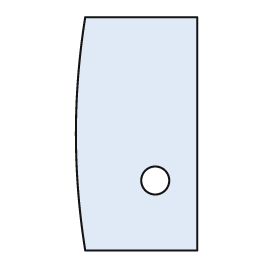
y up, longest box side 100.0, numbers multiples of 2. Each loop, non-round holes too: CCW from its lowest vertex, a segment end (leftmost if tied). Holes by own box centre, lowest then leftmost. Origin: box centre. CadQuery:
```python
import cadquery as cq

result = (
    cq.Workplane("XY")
    .moveTo(-22.0, -50.0)
    .lineTo(26.0, -50.0)
    .lineTo(26.0, 50.0)
    .lineTo(-22.0, 50.0)
    .threePointArc((-26.0, 0.0), (-22.0, -50.0))
    .close()
    .moveTo(8.0, -20.0)
    .circle(6.0)
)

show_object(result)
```